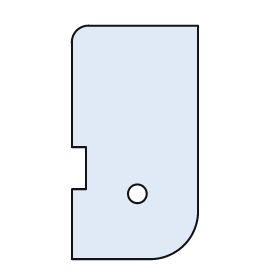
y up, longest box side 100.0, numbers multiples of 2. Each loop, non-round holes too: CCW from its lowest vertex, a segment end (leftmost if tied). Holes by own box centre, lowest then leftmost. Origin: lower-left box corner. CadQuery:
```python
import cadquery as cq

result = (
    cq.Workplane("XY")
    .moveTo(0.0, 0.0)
    .lineTo(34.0, 0.0)
    .threePointArc((48.0, 6.0), (54.0, 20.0))
    .lineTo(54.0, 100.0)
    .lineTo(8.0, 100.0)
    .threePointArc((2.0, 98.0), (0.0, 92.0))
    .lineTo(0.0, 48.0)
    .lineTo(6.0, 48.0)
    .lineTo(6.0, 30.0)
    .lineTo(0.0, 30.0)
    .close()
    .moveTo(28.0, 28.0)
    .circle(4.0)
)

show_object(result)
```